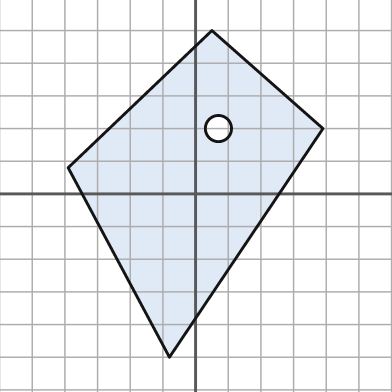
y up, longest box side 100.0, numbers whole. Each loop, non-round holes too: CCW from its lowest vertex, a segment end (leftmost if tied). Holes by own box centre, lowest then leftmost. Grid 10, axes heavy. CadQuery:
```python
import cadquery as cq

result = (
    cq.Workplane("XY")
    .moveTo(-8.0, -50.0)
    .lineTo(39.0, 20.0)
    .lineTo(5.0, 50.0)
    .lineTo(-39.0, 8.0)
    .close()
    .moveTo(7.0, 20.0)
    .circle(4.0)
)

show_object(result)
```